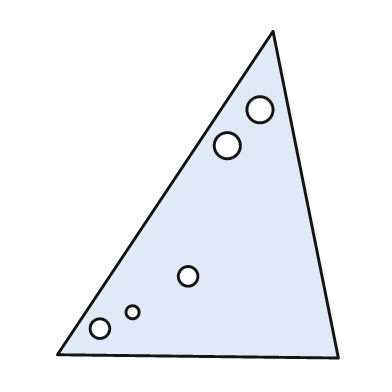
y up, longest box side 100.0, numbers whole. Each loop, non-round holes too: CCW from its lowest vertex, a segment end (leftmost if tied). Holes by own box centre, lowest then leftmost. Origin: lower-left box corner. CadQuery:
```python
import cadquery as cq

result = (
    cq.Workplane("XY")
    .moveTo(86.0, 0.0)
    .lineTo(66.0, 100.0)
    .lineTo(0.0, 1.0)
    .close()
    .moveTo(13.0, 9.0)
    .circle(3.0)
    .moveTo(23.0, 14.0)
    .circle(2.0)
    .moveTo(40.0, 25.0)
    .circle(3.0)
    .moveTo(52.0, 65.0)
    .circle(4.0)
    .moveTo(62.0, 76.0)
    .circle(4.0)
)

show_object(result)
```